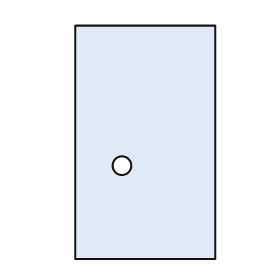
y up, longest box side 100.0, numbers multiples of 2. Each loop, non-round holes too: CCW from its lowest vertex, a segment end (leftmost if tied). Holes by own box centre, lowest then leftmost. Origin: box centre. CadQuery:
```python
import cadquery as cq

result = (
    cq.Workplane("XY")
    .moveTo(-30.0, -50.0)
    .lineTo(30.0, -50.0)
    .lineTo(30.0, 50.0)
    .lineTo(-30.0, 50.0)
    .close()
    .moveTo(-10.0, -10.0)
    .circle(4.0)
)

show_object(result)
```